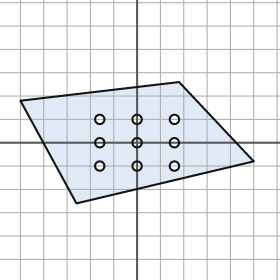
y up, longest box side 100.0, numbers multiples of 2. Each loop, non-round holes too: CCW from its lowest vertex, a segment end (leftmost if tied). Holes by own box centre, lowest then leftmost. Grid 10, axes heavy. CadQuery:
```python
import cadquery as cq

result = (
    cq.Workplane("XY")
    .moveTo(-26.0, -26.0)
    .lineTo(50.0, -8.0)
    .lineTo(18.0, 26.0)
    .lineTo(-50.0, 18.0)
    .close()
    .moveTo(-16.0, -10.0)
    .circle(2.0)
    .moveTo(0.0, -10.0)
    .circle(2.0)
    .moveTo(16.0, -10.0)
    .circle(2.0)
    .moveTo(-16.0, 0.0)
    .circle(2.0)
    .moveTo(0.0, 0.0)
    .circle(2.0)
    .moveTo(16.0, 0.0)
    .circle(2.0)
    .moveTo(-16.0, 10.0)
    .circle(2.0)
    .moveTo(0.0, 10.0)
    .circle(2.0)
    .moveTo(16.0, 10.0)
    .circle(2.0)
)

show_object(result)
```